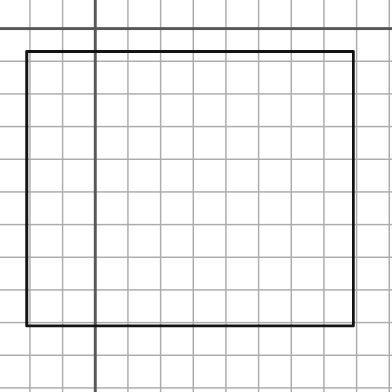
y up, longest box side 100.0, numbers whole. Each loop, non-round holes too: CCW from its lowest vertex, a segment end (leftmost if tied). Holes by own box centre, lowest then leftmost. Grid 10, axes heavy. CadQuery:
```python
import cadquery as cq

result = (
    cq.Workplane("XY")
    .moveTo(-21.0, -91.0)
    .lineTo(79.0, -91.0)
    .lineTo(79.0, -7.0)
    .lineTo(-21.0, -7.0)
    .close()
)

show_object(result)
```